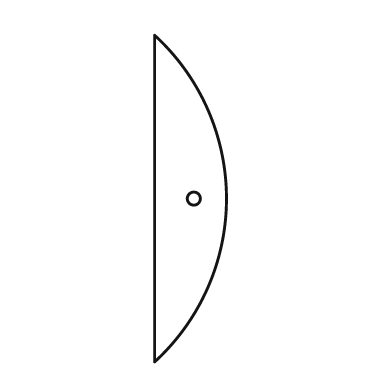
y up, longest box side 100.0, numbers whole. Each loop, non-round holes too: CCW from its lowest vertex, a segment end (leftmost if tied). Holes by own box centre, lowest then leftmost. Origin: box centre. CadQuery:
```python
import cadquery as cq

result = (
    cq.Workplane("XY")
    .moveTo(-11.0, -50.0)
    .threePointArc((11.0, 0.0), (-11.0, 50.0))
    .close()
    .moveTo(1.0, 0.0)
    .circle(2.0)
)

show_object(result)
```